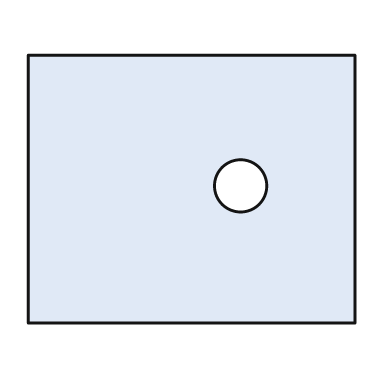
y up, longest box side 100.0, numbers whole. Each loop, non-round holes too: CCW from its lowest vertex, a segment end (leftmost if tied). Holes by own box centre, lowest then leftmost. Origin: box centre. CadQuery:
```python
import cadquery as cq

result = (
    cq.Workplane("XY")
    .moveTo(-50.0, -41.0)
    .lineTo(50.0, -41.0)
    .lineTo(50.0, 41.0)
    .lineTo(-50.0, 41.0)
    .close()
    .moveTo(15.0, 1.0)
    .circle(8.0)
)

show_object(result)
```